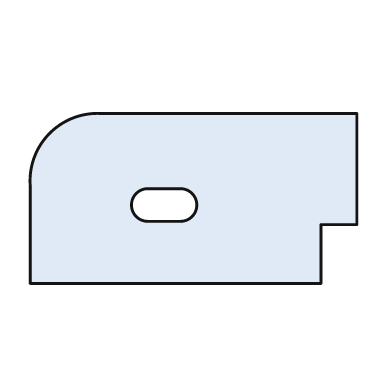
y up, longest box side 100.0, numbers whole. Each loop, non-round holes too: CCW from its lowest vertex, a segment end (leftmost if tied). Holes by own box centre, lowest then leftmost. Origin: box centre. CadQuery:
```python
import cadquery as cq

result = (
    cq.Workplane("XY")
    .moveTo(-50.0, -26.0)
    .lineTo(39.0, -26.0)
    .lineTo(39.0, -8.0)
    .lineTo(50.0, -8.0)
    .lineTo(50.0, 26.0)
    .lineTo(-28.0, 26.0)
    .threePointArc((-44.0, 20.0), (-50.0, 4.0))
    .close()
    .moveTo(-14.0, -7.0)
    .lineTo(-4.0, -7.0)
    .threePointArc((1.0, -2.0), (-4.0, 3.0))
    .lineTo(-14.0, 3.0)
    .threePointArc((-19.0, -2.0), (-14.0, -7.0))
    .close()
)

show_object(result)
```